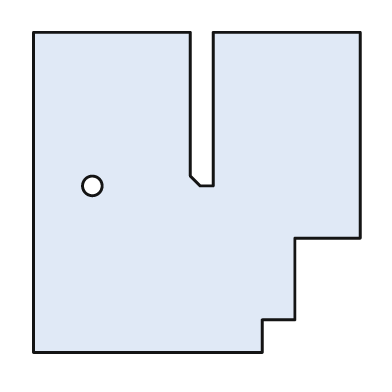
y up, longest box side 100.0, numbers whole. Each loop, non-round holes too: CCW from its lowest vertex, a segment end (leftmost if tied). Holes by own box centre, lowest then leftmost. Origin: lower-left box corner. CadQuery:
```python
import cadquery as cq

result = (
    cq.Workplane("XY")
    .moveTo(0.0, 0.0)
    .lineTo(70.0, 0.0)
    .lineTo(70.0, 10.0)
    .lineTo(80.0, 10.0)
    .lineTo(80.0, 35.0)
    .lineTo(100.0, 35.0)
    .lineTo(100.0, 98.0)
    .lineTo(55.0, 98.0)
    .lineTo(55.0, 51.0)
    .lineTo(51.0, 51.0)
    .lineTo(48.0, 54.0)
    .lineTo(48.0, 98.0)
    .lineTo(0.0, 98.0)
    .close()
    .moveTo(18.0, 51.0)
    .circle(3.0)
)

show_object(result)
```